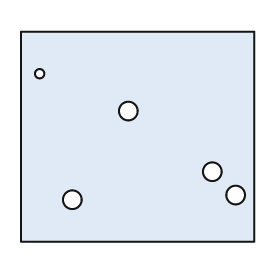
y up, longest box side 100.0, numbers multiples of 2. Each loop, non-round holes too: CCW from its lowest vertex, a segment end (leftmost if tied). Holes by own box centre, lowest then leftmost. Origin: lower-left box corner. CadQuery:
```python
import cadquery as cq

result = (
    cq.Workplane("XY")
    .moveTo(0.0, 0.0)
    .lineTo(100.0, 0.0)
    .lineTo(100.0, 90.0)
    .lineTo(0.0, 90.0)
    .close()
    .moveTo(22.0, 18.0)
    .circle(4.0)
    .moveTo(92.0, 20.0)
    .circle(4.0)
    .moveTo(82.0, 30.0)
    .circle(4.0)
    .moveTo(46.0, 56.0)
    .circle(4.0)
    .moveTo(8.0, 72.0)
    .circle(2.0)
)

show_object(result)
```